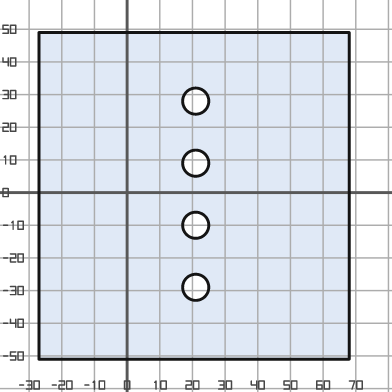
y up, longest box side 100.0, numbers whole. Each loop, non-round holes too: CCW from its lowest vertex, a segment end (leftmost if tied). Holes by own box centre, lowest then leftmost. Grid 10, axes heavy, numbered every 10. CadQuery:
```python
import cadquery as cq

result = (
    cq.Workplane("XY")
    .moveTo(-27.0, -51.0)
    .lineTo(68.0, -51.0)
    .lineTo(68.0, 49.0)
    .lineTo(-27.0, 49.0)
    .close()
    .moveTo(21.0, -29.0)
    .circle(4.0)
    .moveTo(21.0, -10.0)
    .circle(4.0)
    .moveTo(21.0, 9.0)
    .circle(4.0)
    .moveTo(21.0, 28.0)
    .circle(4.0)
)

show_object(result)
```